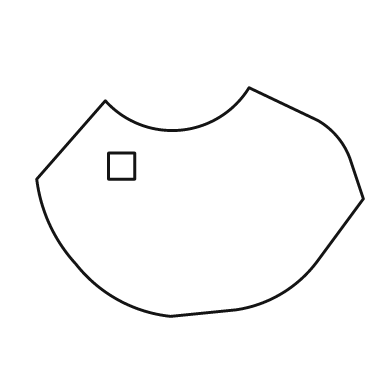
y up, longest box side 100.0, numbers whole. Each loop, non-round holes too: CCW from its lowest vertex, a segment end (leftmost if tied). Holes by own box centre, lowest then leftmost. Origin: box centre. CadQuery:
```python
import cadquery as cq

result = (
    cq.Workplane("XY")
    .moveTo(-9.0, -35.0)
    .lineTo(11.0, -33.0)
    .threePointArc((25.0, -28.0), (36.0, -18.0))
    .lineTo(50.0, 1.0)
    .lineTo(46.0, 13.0)
    .threePointArc((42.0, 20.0), (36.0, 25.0))
    .lineTo(15.0, 35.0)
    .threePointArc((-6.0, 22.0), (-29.0, 31.0))
    .lineTo(-50.0, 7.0)
    .threePointArc((-46.0, -7.0), (-38.0, -19.0))
    .threePointArc((-25.0, -30.0), (-9.0, -35.0))
    .close()
    .moveTo(-28.0, 7.0)
    .lineTo(-20.0, 7.0)
    .lineTo(-20.0, 15.0)
    .lineTo(-28.0, 15.0)
    .close()
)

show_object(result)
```